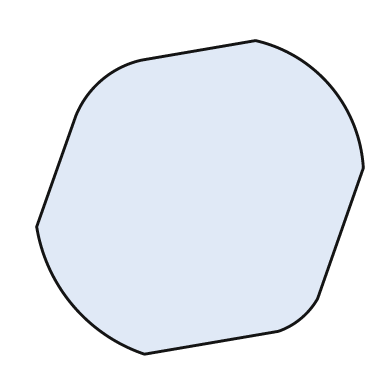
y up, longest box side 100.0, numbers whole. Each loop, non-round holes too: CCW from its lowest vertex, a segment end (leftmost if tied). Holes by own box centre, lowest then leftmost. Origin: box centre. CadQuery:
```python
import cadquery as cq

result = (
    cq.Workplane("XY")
    .moveTo(-17.0, -48.0)
    .lineTo(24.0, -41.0)
    .threePointArc((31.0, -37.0), (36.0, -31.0))
    .lineTo(50.0, 9.0)
    .threePointArc((40.0, 34.0), (17.0, 48.0))
    .lineTo(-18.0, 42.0)
    .threePointArc((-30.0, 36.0), (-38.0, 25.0))
    .lineTo(-50.0, -9.0)
    .threePointArc((-39.0, -33.0), (-17.0, -48.0))
    .close()
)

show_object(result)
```